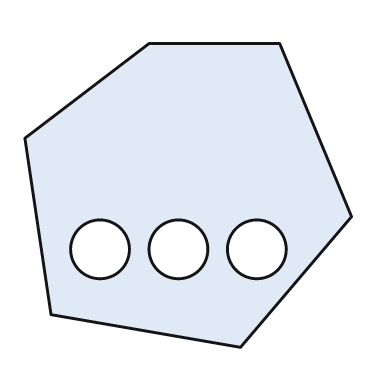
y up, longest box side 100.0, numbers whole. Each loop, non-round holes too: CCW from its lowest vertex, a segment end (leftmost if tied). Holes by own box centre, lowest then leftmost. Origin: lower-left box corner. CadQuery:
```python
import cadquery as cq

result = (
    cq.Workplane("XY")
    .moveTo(66.0, 0.0)
    .lineTo(100.0, 40.0)
    .lineTo(78.0, 93.0)
    .lineTo(38.0, 93.0)
    .lineTo(0.0, 64.0)
    .lineTo(8.0, 10.0)
    .close()
    .moveTo(23.0, 30.0)
    .circle(9.0)
    .moveTo(47.0, 30.0)
    .circle(9.0)
    .moveTo(71.0, 30.0)
    .circle(9.0)
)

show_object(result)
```